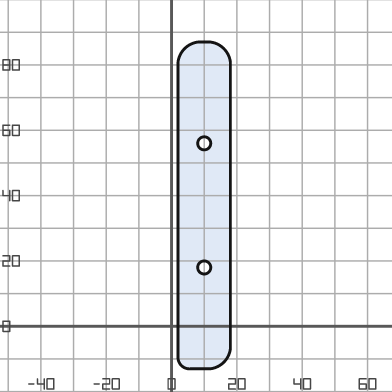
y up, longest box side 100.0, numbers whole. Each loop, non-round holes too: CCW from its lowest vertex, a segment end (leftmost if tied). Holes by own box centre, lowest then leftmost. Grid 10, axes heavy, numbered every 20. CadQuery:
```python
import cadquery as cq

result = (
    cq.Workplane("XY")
    .moveTo(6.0, -13.0)
    .lineTo(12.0, -13.0)
    .threePointArc((16.0, -11.0), (18.0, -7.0))
    .lineTo(18.0, 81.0)
    .threePointArc((16.0, 85.0), (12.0, 87.0))
    .lineTo(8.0, 87.0)
    .threePointArc((4.0, 85.0), (2.0, 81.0))
    .lineTo(2.0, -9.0)
    .threePointArc((3.0, -12.0), (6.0, -13.0))
    .close()
    .moveTo(10.0, 18.0)
    .circle(2.0)
    .moveTo(10.0, 56.0)
    .circle(2.0)
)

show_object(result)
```